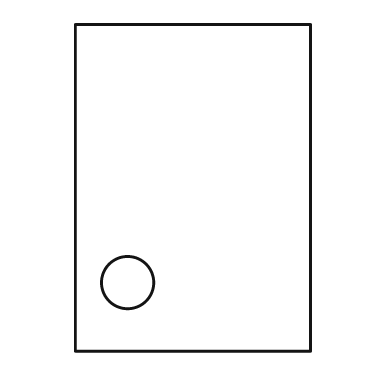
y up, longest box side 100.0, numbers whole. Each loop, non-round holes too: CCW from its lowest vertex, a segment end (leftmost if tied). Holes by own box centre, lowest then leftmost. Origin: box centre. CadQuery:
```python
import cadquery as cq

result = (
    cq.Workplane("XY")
    .moveTo(-36.0, -50.0)
    .lineTo(36.0, -50.0)
    .lineTo(36.0, 50.0)
    .lineTo(-36.0, 50.0)
    .close()
    .moveTo(-20.0, -29.0)
    .circle(8.0)
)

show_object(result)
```